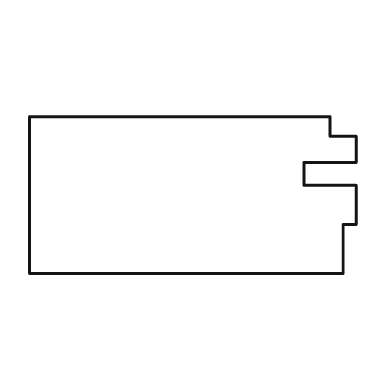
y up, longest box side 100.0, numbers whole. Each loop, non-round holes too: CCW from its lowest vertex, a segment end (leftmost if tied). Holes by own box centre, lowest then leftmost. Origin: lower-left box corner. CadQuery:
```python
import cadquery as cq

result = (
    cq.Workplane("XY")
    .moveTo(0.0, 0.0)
    .lineTo(96.0, 0.0)
    .lineTo(96.0, 15.0)
    .lineTo(100.0, 15.0)
    .lineTo(100.0, 27.0)
    .lineTo(84.0, 27.0)
    .lineTo(84.0, 34.0)
    .lineTo(100.0, 34.0)
    .lineTo(100.0, 42.0)
    .lineTo(92.0, 42.0)
    .lineTo(92.0, 48.0)
    .lineTo(0.0, 48.0)
    .close()
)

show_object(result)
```